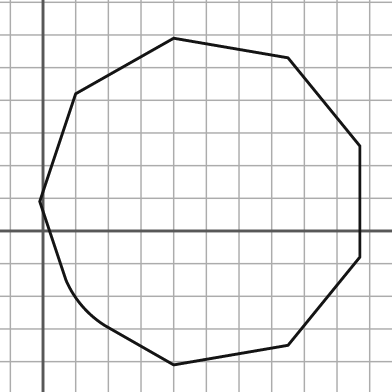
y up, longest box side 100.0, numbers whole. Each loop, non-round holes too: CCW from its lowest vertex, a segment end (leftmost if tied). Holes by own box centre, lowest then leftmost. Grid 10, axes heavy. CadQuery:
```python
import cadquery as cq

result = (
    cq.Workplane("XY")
    .moveTo(40.0, -41.0)
    .lineTo(75.0, -35.0)
    .lineTo(97.0, -8.0)
    .lineTo(97.0, 26.0)
    .lineTo(75.0, 53.0)
    .lineTo(40.0, 59.0)
    .lineTo(10.0, 42.0)
    .lineTo(-1.0, 9.0)
    .lineTo(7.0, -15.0)
    .threePointArc((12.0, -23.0), (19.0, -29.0))
    .close()
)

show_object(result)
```